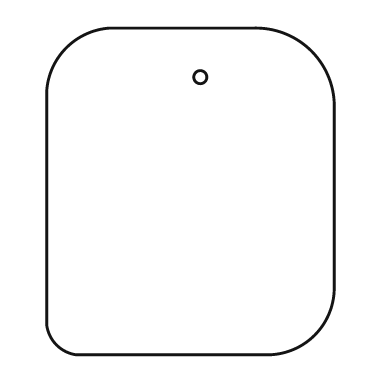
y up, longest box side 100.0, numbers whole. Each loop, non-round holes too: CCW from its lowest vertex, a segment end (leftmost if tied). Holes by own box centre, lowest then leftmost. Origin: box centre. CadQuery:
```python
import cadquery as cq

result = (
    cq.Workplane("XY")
    .moveTo(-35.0, -50.0)
    .lineTo(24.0, -50.0)
    .threePointArc((38.0, -44.0), (44.0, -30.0))
    .lineTo(44.0, 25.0)
    .threePointArc((37.0, 43.0), (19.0, 50.0))
    .lineTo(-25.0, 50.0)
    .threePointArc((-38.0, 44.0), (-44.0, 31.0))
    .lineTo(-44.0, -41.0)
    .threePointArc((-41.0, -47.0), (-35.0, -50.0))
    .close()
    .moveTo(3.0, 35.0)
    .circle(2.0)
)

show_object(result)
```